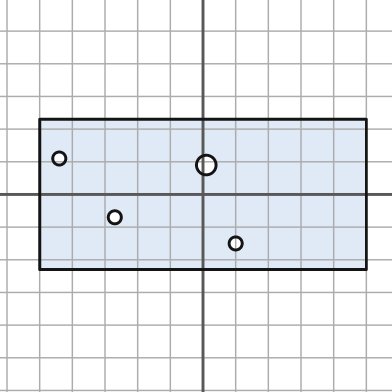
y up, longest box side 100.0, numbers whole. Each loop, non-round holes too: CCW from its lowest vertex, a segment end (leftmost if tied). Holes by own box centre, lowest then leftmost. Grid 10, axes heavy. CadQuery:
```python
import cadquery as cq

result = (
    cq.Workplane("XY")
    .moveTo(-50.0, -23.0)
    .lineTo(50.0, -23.0)
    .lineTo(50.0, 23.0)
    .lineTo(-50.0, 23.0)
    .close()
    .moveTo(10.0, -15.0)
    .circle(2.0)
    .moveTo(-27.0, -7.0)
    .circle(2.0)
    .moveTo(1.0, 9.0)
    .circle(3.0)
    .moveTo(-44.0, 11.0)
    .circle(2.0)
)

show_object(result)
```